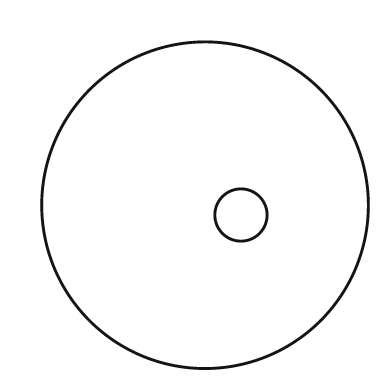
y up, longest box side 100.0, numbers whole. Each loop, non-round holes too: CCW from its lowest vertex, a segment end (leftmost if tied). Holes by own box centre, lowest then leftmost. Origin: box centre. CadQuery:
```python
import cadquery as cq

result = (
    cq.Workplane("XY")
    .moveTo(0.0, 0.0)
    .circle(50.0)
    .moveTo(11.0, -3.0)
    .circle(8.0)
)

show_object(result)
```